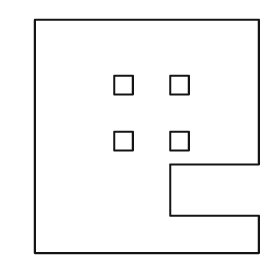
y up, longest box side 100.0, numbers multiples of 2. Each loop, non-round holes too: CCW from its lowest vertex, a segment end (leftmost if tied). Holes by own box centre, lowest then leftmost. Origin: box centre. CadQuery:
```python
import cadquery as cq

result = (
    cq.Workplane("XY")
    .moveTo(-48.0, -50.0)
    .lineTo(48.0, -50.0)
    .lineTo(48.0, -34.0)
    .lineTo(10.0, -34.0)
    .lineTo(10.0, -12.0)
    .lineTo(48.0, -12.0)
    .lineTo(48.0, 50.0)
    .lineTo(-48.0, 50.0)
    .close()
    .moveTo(-14.0, -6.0)
    .lineTo(-6.0, -6.0)
    .lineTo(-6.0, 2.0)
    .lineTo(-14.0, 2.0)
    .close()
    .moveTo(10.0, -6.0)
    .lineTo(18.0, -6.0)
    .lineTo(18.0, 2.0)
    .lineTo(10.0, 2.0)
    .close()
    .moveTo(-14.0, 18.0)
    .lineTo(-6.0, 18.0)
    .lineTo(-6.0, 26.0)
    .lineTo(-14.0, 26.0)
    .close()
    .moveTo(10.0, 18.0)
    .lineTo(18.0, 18.0)
    .lineTo(18.0, 26.0)
    .lineTo(10.0, 26.0)
    .close()
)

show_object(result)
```